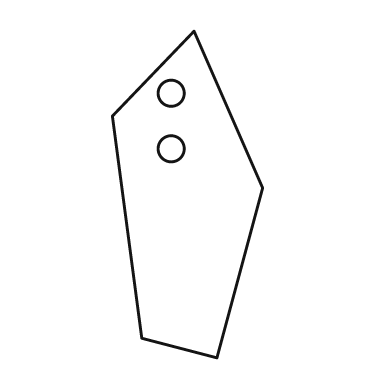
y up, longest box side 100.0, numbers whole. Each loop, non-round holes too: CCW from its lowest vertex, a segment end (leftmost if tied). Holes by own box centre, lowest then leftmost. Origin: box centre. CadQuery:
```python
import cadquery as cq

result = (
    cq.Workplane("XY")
    .moveTo(9.0, -50.0)
    .lineTo(23.0, 2.0)
    .lineTo(2.0, 50.0)
    .lineTo(-23.0, 24.0)
    .lineTo(-14.0, -44.0)
    .close()
    .moveTo(-5.0, 14.0)
    .circle(4.0)
    .moveTo(-5.0, 31.0)
    .circle(4.0)
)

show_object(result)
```